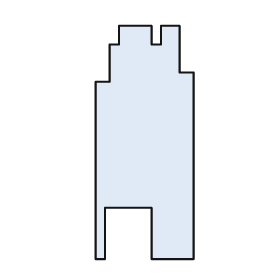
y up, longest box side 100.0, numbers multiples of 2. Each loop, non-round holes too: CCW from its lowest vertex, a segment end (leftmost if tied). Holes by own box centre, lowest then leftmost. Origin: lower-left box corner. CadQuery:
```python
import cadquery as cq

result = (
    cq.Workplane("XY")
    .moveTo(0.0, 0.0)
    .lineTo(4.0, 0.0)
    .lineTo(4.0, 22.0)
    .lineTo(24.0, 22.0)
    .lineTo(24.0, 0.0)
    .lineTo(42.0, 0.0)
    .lineTo(42.0, 80.0)
    .lineTo(36.0, 80.0)
    .lineTo(36.0, 100.0)
    .lineTo(28.0, 100.0)
    .lineTo(28.0, 92.0)
    .lineTo(24.0, 92.0)
    .lineTo(24.0, 100.0)
    .lineTo(10.0, 100.0)
    .lineTo(10.0, 92.0)
    .lineTo(6.0, 92.0)
    .lineTo(6.0, 76.0)
    .lineTo(0.0, 76.0)
    .close()
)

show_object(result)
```